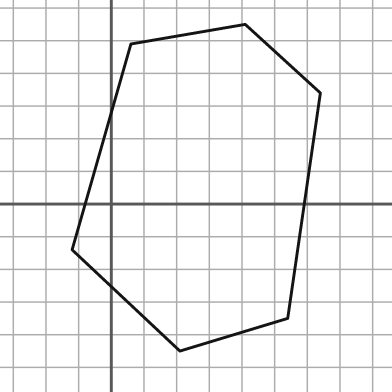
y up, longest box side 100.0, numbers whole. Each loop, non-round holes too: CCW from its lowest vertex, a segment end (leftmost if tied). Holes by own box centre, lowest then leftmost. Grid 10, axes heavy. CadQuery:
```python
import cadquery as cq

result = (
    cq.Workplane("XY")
    .moveTo(21.0, -45.0)
    .lineTo(54.0, -35.0)
    .lineTo(64.0, 34.0)
    .lineTo(41.0, 55.0)
    .lineTo(6.0, 49.0)
    .lineTo(-12.0, -14.0)
    .close()
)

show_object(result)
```